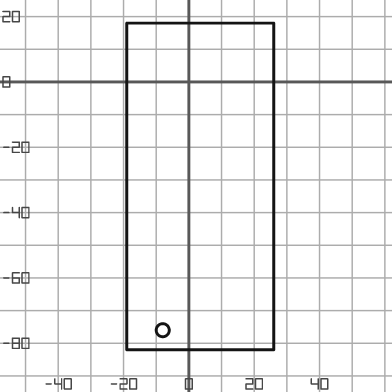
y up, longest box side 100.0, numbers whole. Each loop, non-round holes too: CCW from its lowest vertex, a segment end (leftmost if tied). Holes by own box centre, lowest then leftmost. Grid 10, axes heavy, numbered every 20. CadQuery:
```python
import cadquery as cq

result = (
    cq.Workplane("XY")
    .moveTo(-19.0, -82.0)
    .lineTo(26.0, -82.0)
    .lineTo(26.0, 18.0)
    .lineTo(-19.0, 18.0)
    .close()
    .moveTo(-8.0, -76.0)
    .circle(2.0)
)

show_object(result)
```